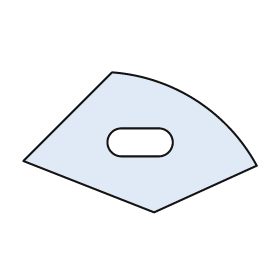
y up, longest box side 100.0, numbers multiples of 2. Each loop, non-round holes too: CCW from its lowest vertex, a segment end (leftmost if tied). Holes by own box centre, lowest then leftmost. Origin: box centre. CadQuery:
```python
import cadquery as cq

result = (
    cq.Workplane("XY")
    .moveTo(6.0, -30.0)
    .lineTo(50.0, -10.0)
    .threePointArc((24.0, 18.0), (-12.0, 30.0))
    .lineTo(-50.0, -8.0)
    .close()
    .moveTo(-8.0, -6.0)
    .lineTo(8.0, -6.0)
    .threePointArc((14.0, 0.0), (8.0, 6.0))
    .lineTo(-8.0, 6.0)
    .threePointArc((-14.0, 0.0), (-8.0, -6.0))
    .close()
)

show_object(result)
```